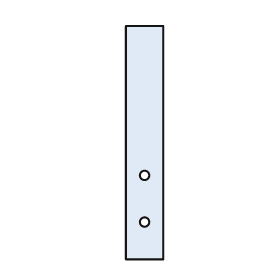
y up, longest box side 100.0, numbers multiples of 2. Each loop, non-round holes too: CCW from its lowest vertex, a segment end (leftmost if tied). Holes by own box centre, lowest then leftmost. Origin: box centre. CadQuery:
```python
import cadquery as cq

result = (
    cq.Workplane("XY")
    .moveTo(-8.0, -50.0)
    .lineTo(8.0, -50.0)
    .lineTo(8.0, 50.0)
    .lineTo(-8.0, 50.0)
    .close()
    .moveTo(0.0, -34.0)
    .circle(2.0)
    .moveTo(0.0, -14.0)
    .circle(2.0)
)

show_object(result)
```